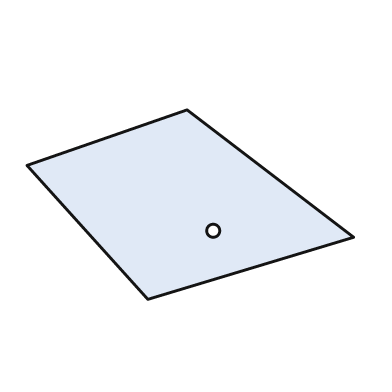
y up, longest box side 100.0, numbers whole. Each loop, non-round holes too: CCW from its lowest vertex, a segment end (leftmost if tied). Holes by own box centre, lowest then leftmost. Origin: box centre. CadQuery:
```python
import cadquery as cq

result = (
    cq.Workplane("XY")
    .moveTo(-13.0, -29.0)
    .lineTo(50.0, -10.0)
    .lineTo(-1.0, 29.0)
    .lineTo(-50.0, 12.0)
    .close()
    .moveTo(7.0, -8.0)
    .circle(2.0)
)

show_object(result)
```